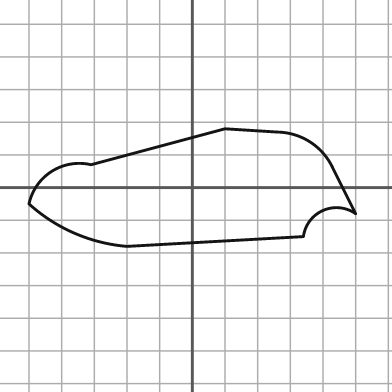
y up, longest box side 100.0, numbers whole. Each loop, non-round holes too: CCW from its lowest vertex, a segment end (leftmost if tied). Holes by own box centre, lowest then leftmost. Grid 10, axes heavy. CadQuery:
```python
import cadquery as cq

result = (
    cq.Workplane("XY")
    .moveTo(-20.0, -18.0)
    .lineTo(34.0, -15.0)
    .threePointArc((40.0, -7.0), (50.0, -8.0))
    .lineTo(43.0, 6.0)
    .threePointArc((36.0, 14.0), (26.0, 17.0))
    .lineTo(10.0, 18.0)
    .lineTo(-31.0, 7.0)
    .threePointArc((-43.0, 5.0), (-50.0, -5.0))
    .threePointArc((-36.0, -14.0), (-20.0, -18.0))
    .close()
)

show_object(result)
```